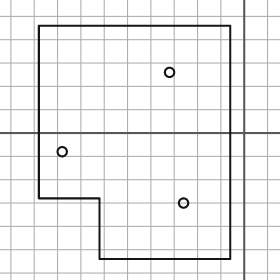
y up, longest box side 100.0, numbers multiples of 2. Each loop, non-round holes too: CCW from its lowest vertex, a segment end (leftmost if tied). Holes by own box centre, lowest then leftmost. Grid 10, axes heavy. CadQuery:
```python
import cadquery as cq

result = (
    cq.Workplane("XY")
    .moveTo(-62.0, -54.0)
    .lineTo(-6.0, -54.0)
    .lineTo(-6.0, 46.0)
    .lineTo(-88.0, 46.0)
    .lineTo(-88.0, -28.0)
    .lineTo(-62.0, -28.0)
    .close()
    .moveTo(-26.0, -30.0)
    .circle(2.0)
    .moveTo(-78.0, -8.0)
    .circle(2.0)
    .moveTo(-32.0, 26.0)
    .circle(2.0)
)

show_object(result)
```